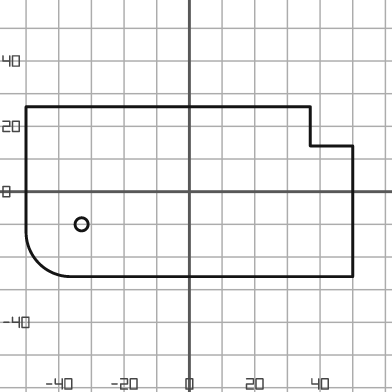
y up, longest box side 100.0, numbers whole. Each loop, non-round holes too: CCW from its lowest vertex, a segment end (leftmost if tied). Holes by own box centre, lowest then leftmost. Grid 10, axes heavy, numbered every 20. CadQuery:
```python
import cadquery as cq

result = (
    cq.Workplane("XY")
    .moveTo(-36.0, -26.0)
    .lineTo(50.0, -26.0)
    .lineTo(50.0, 14.0)
    .lineTo(37.0, 14.0)
    .lineTo(37.0, 26.0)
    .lineTo(-50.0, 26.0)
    .lineTo(-50.0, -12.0)
    .threePointArc((-46.0, -22.0), (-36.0, -26.0))
    .close()
    .moveTo(-33.0, -10.0)
    .circle(2.0)
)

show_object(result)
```